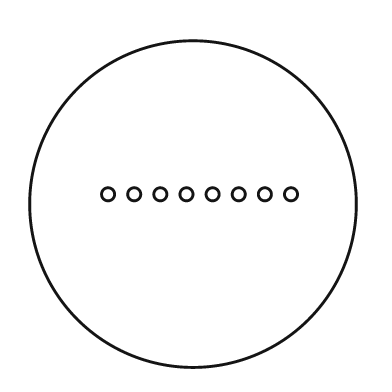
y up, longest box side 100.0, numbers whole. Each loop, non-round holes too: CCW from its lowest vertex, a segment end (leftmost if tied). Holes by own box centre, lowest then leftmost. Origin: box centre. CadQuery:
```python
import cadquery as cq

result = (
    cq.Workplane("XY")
    .moveTo(0.0, 0.0)
    .circle(50.0)
    .moveTo(-26.0, 3.0)
    .circle(2.0)
    .moveTo(-18.0, 3.0)
    .circle(2.0)
    .moveTo(-10.0, 3.0)
    .circle(2.0)
    .moveTo(-2.0, 3.0)
    .circle(2.0)
    .moveTo(6.0, 3.0)
    .circle(2.0)
    .moveTo(14.0, 3.0)
    .circle(2.0)
    .moveTo(22.0, 3.0)
    .circle(2.0)
    .moveTo(30.0, 3.0)
    .circle(2.0)
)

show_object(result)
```